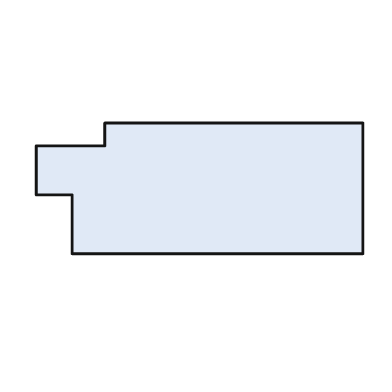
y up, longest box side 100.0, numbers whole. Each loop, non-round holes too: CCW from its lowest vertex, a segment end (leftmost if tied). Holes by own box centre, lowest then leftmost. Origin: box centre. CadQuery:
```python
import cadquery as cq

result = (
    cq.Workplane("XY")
    .moveTo(-39.0, -20.0)
    .lineTo(50.0, -20.0)
    .lineTo(50.0, 20.0)
    .lineTo(-29.0, 20.0)
    .lineTo(-29.0, 13.0)
    .lineTo(-50.0, 13.0)
    .lineTo(-50.0, -2.0)
    .lineTo(-39.0, -2.0)
    .close()
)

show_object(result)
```